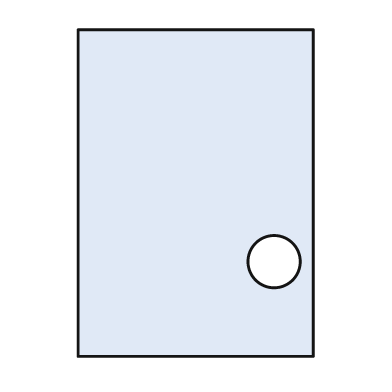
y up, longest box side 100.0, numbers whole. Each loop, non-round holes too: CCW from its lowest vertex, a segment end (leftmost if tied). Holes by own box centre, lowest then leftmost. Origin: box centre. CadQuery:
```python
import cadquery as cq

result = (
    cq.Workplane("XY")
    .moveTo(-36.0, -50.0)
    .lineTo(36.0, -50.0)
    .lineTo(36.0, 50.0)
    .lineTo(-36.0, 50.0)
    .close()
    .moveTo(24.0, -21.0)
    .circle(8.0)
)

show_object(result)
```